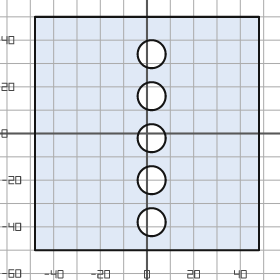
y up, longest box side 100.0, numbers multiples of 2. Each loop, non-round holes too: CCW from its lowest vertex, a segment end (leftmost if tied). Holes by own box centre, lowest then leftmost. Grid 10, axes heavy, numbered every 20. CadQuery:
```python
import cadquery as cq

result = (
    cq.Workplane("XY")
    .moveTo(-48.0, -50.0)
    .lineTo(48.0, -50.0)
    .lineTo(48.0, 50.0)
    .lineTo(-48.0, 50.0)
    .close()
    .moveTo(2.0, -38.0)
    .circle(6.0)
    .moveTo(2.0, -20.0)
    .circle(6.0)
    .moveTo(2.0, -2.0)
    .circle(6.0)
    .moveTo(2.0, 16.0)
    .circle(6.0)
    .moveTo(2.0, 34.0)
    .circle(6.0)
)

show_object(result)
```